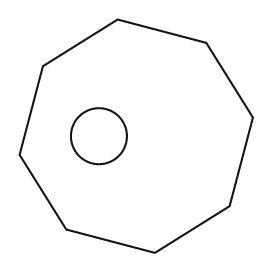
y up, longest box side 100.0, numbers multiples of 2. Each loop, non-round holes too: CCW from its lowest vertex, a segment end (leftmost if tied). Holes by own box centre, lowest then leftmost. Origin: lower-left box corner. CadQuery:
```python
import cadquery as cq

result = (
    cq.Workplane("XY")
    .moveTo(58.0, 0.0)
    .lineTo(90.0, 20.0)
    .lineTo(100.0, 58.0)
    .lineTo(80.0, 90.0)
    .lineTo(42.0, 100.0)
    .lineTo(10.0, 80.0)
    .lineTo(0.0, 42.0)
    .lineTo(20.0, 10.0)
    .close()
    .moveTo(34.0, 50.0)
    .circle(12.0)
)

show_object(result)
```